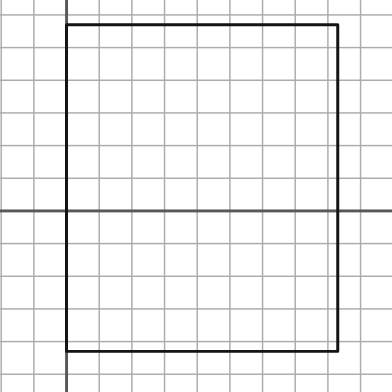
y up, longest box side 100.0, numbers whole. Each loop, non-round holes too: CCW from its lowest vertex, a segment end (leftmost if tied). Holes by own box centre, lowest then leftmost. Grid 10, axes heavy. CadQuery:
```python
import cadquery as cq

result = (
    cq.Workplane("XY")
    .moveTo(0.0, -43.0)
    .lineTo(83.0, -43.0)
    .lineTo(83.0, 57.0)
    .lineTo(0.0, 57.0)
    .close()
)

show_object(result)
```